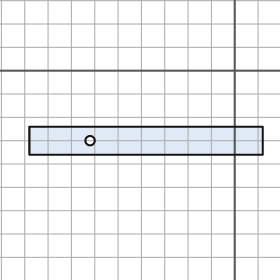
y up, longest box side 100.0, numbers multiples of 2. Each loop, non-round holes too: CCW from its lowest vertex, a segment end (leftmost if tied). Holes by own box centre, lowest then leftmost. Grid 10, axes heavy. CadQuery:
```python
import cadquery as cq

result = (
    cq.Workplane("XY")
    .moveTo(-88.0, -36.0)
    .lineTo(12.0, -36.0)
    .lineTo(12.0, -24.0)
    .lineTo(-88.0, -24.0)
    .close()
    .moveTo(-62.0, -30.0)
    .circle(2.0)
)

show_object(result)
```